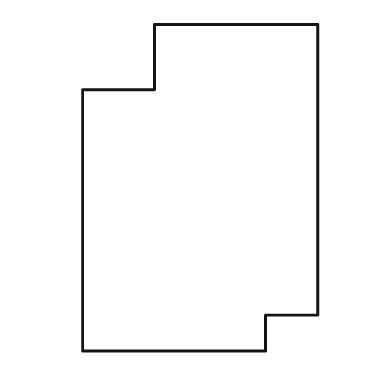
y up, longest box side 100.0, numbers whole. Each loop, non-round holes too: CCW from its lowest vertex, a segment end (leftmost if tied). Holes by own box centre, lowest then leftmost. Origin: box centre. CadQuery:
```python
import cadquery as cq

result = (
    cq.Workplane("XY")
    .moveTo(-36.0, -50.0)
    .lineTo(20.0, -50.0)
    .lineTo(20.0, -39.0)
    .lineTo(36.0, -39.0)
    .lineTo(36.0, 50.0)
    .lineTo(-14.0, 50.0)
    .lineTo(-14.0, 30.0)
    .lineTo(-36.0, 30.0)
    .close()
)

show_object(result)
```